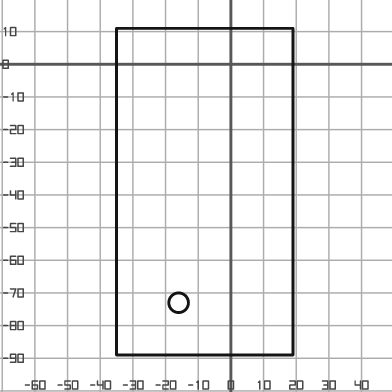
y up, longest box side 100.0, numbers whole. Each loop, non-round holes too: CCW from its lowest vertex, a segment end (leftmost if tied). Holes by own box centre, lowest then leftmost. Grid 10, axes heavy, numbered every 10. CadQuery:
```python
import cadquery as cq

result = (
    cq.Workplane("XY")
    .moveTo(-35.0, -89.0)
    .lineTo(19.0, -89.0)
    .lineTo(19.0, 11.0)
    .lineTo(-35.0, 11.0)
    .close()
    .moveTo(-16.0, -73.0)
    .circle(3.0)
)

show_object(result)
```